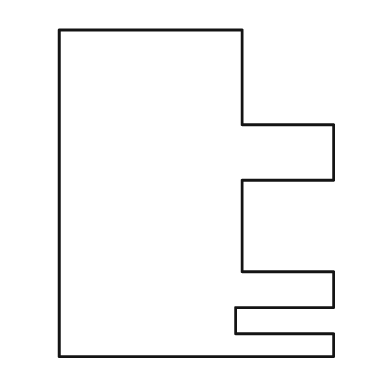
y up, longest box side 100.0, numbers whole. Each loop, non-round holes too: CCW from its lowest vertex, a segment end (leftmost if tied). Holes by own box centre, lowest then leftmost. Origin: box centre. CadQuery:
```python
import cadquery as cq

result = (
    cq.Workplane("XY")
    .moveTo(-42.0, -50.0)
    .lineTo(42.0, -50.0)
    .lineTo(42.0, -43.0)
    .lineTo(12.0, -43.0)
    .lineTo(12.0, -35.0)
    .lineTo(42.0, -35.0)
    .lineTo(42.0, -24.0)
    .lineTo(14.0, -24.0)
    .lineTo(14.0, 4.0)
    .lineTo(42.0, 4.0)
    .lineTo(42.0, 21.0)
    .lineTo(14.0, 21.0)
    .lineTo(14.0, 50.0)
    .lineTo(-42.0, 50.0)
    .close()
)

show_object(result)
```